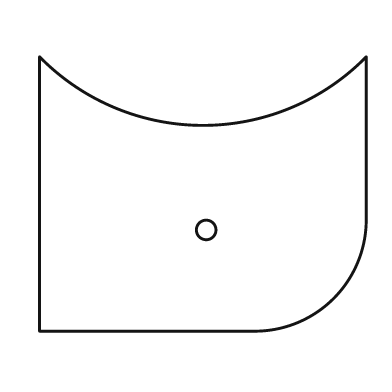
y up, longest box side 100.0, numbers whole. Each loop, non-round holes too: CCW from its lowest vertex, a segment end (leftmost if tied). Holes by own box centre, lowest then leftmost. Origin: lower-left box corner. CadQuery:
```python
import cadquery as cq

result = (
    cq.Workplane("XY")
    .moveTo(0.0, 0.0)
    .lineTo(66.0, 0.0)
    .threePointArc((90.0, 10.0), (100.0, 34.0))
    .lineTo(100.0, 84.0)
    .threePointArc((50.0, 63.0), (0.0, 84.0))
    .close()
    .moveTo(51.0, 31.0)
    .circle(3.0)
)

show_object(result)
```